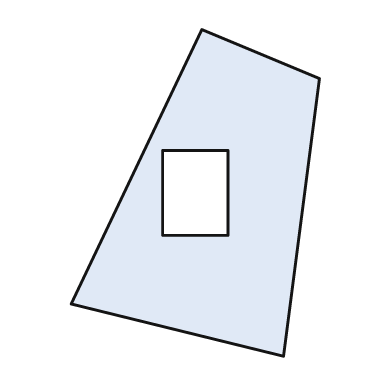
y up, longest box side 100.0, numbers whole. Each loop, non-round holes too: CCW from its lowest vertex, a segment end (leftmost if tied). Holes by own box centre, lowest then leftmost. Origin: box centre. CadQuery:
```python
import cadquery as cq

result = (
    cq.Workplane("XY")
    .moveTo(27.0, -50.0)
    .lineTo(38.0, 35.0)
    .lineTo(2.0, 50.0)
    .lineTo(-38.0, -34.0)
    .close()
    .moveTo(-10.0, -13.0)
    .lineTo(10.0, -13.0)
    .lineTo(10.0, 13.0)
    .lineTo(-10.0, 13.0)
    .close()
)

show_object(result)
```